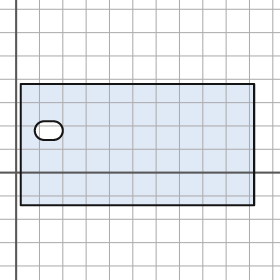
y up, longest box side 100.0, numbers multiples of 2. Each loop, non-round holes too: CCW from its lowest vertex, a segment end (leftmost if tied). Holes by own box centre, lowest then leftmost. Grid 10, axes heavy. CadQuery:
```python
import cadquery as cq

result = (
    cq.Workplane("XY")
    .moveTo(2.0, -14.0)
    .lineTo(102.0, -14.0)
    .lineTo(102.0, 38.0)
    .lineTo(2.0, 38.0)
    .close()
    .moveTo(12.0, 14.0)
    .lineTo(16.0, 14.0)
    .threePointArc((20.0, 18.0), (16.0, 22.0))
    .lineTo(12.0, 22.0)
    .threePointArc((8.0, 18.0), (12.0, 14.0))
    .close()
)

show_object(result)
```